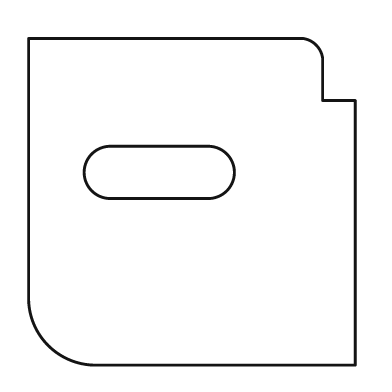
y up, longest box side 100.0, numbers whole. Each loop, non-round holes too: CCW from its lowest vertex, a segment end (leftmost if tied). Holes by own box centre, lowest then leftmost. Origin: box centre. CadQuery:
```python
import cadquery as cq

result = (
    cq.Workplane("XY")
    .moveTo(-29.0, -50.0)
    .lineTo(50.0, -50.0)
    .lineTo(50.0, 31.0)
    .lineTo(40.0, 31.0)
    .lineTo(40.0, 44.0)
    .threePointArc((38.0, 48.0), (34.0, 50.0))
    .lineTo(-50.0, 50.0)
    .lineTo(-50.0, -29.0)
    .threePointArc((-44.0, -44.0), (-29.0, -50.0))
    .close()
    .moveTo(-25.0, 1.0)
    .lineTo(5.0, 1.0)
    .threePointArc((13.0, 9.0), (5.0, 17.0))
    .lineTo(-25.0, 17.0)
    .threePointArc((-33.0, 9.0), (-25.0, 1.0))
    .close()
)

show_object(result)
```